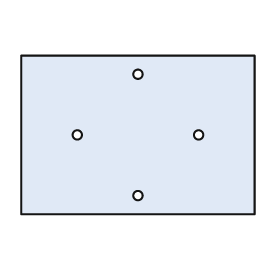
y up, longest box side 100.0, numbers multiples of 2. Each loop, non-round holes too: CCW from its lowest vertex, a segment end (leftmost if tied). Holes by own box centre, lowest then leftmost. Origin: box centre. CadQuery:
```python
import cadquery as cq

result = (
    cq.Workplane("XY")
    .moveTo(-50.0, -34.0)
    .lineTo(50.0, -34.0)
    .lineTo(50.0, 34.0)
    .lineTo(-50.0, 34.0)
    .close()
    .moveTo(0.0, -26.0)
    .circle(2.0)
    .moveTo(-26.0, 0.0)
    .circle(2.0)
    .moveTo(26.0, 0.0)
    .circle(2.0)
    .moveTo(0.0, 26.0)
    .circle(2.0)
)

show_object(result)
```